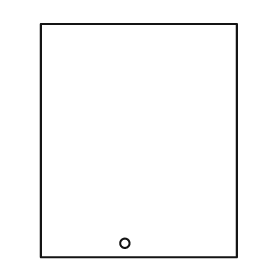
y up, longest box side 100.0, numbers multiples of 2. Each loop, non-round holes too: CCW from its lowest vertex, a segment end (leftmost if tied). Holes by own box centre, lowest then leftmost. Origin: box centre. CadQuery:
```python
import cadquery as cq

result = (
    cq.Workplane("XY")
    .moveTo(-42.0, -50.0)
    .lineTo(42.0, -50.0)
    .lineTo(42.0, 50.0)
    .lineTo(-42.0, 50.0)
    .close()
    .moveTo(-6.0, -44.0)
    .circle(2.0)
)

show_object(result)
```